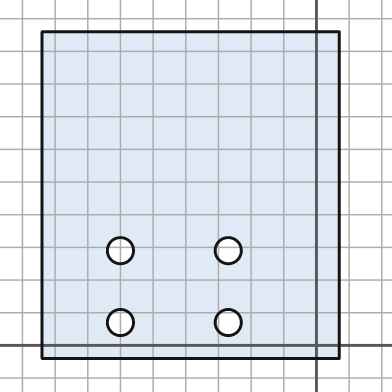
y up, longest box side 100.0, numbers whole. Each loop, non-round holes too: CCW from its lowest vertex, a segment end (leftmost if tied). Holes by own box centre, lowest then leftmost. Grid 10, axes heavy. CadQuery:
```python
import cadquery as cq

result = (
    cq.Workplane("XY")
    .moveTo(-84.0, -4.0)
    .lineTo(7.0, -4.0)
    .lineTo(7.0, 96.0)
    .lineTo(-84.0, 96.0)
    .close()
    .moveTo(-60.0, 7.0)
    .circle(4.0)
    .moveTo(-27.0, 7.0)
    .circle(4.0)
    .moveTo(-60.0, 29.0)
    .circle(4.0)
    .moveTo(-27.0, 29.0)
    .circle(4.0)
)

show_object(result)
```